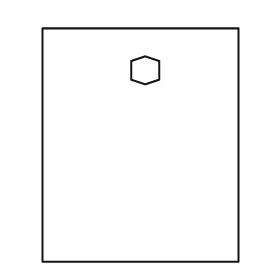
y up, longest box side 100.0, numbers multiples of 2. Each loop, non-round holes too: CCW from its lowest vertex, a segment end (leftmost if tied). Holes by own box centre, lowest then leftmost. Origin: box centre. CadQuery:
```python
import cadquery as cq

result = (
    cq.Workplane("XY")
    .moveTo(-42.0, -50.0)
    .lineTo(42.0, -50.0)
    .lineTo(42.0, 50.0)
    .lineTo(-42.0, 50.0)
    .close()
    .moveTo(2.0, 26.0)
    .lineTo(8.0, 28.0)
    .lineTo(8.0, 36.0)
    .lineTo(2.0, 38.0)
    .lineTo(-4.0, 36.0)
    .lineTo(-4.0, 28.0)
    .close()
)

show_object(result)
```